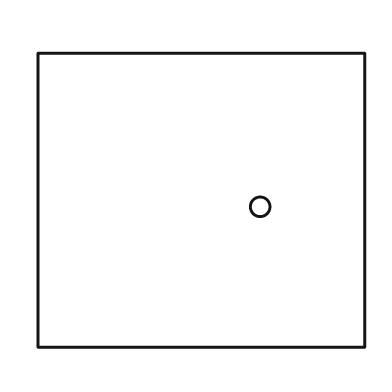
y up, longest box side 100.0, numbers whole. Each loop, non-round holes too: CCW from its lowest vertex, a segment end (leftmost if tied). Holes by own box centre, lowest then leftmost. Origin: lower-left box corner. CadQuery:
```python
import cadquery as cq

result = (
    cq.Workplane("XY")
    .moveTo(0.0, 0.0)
    .lineTo(100.0, 0.0)
    .lineTo(100.0, 90.0)
    .lineTo(0.0, 90.0)
    .close()
    .moveTo(68.0, 43.0)
    .circle(3.0)
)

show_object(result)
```